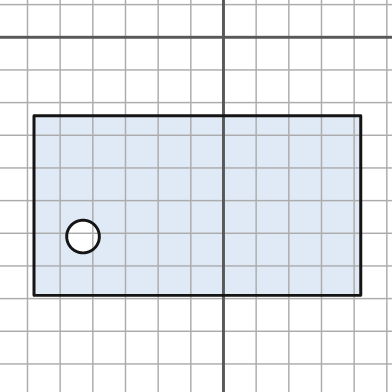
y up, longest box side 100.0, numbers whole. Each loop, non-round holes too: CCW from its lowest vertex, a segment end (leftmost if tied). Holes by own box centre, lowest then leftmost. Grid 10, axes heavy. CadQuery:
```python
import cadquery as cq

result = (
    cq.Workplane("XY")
    .moveTo(-58.0, -79.0)
    .lineTo(42.0, -79.0)
    .lineTo(42.0, -24.0)
    .lineTo(-58.0, -24.0)
    .close()
    .moveTo(-43.0, -61.0)
    .circle(5.0)
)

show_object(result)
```